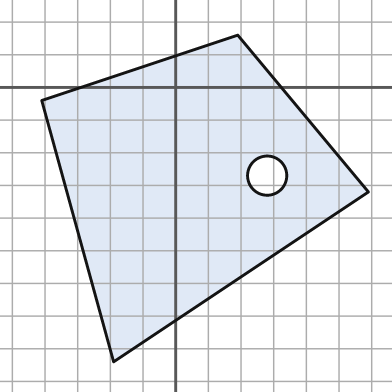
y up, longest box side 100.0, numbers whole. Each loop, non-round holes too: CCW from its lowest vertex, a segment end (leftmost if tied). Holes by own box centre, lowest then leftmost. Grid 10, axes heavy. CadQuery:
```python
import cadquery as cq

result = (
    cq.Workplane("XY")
    .moveTo(-19.0, -84.0)
    .lineTo(59.0, -32.0)
    .lineTo(19.0, 16.0)
    .lineTo(-41.0, -4.0)
    .close()
    .moveTo(28.0, -27.0)
    .circle(6.0)
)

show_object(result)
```